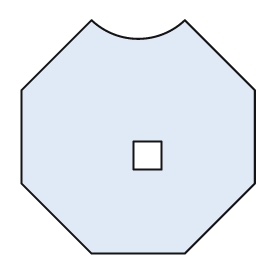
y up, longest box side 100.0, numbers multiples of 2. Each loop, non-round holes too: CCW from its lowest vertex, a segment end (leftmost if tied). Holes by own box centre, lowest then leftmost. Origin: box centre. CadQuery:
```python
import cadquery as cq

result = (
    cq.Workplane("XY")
    .moveTo(-20.0, -50.0)
    .lineTo(20.0, -50.0)
    .lineTo(50.0, -20.0)
    .lineTo(50.0, 20.0)
    .lineTo(20.0, 50.0)
    .threePointArc((0.0, 42.0), (-20.0, 50.0))
    .lineTo(-50.0, 20.0)
    .lineTo(-50.0, -20.0)
    .close()
    .moveTo(-2.0, -14.0)
    .lineTo(10.0, -14.0)
    .lineTo(10.0, -2.0)
    .lineTo(-2.0, -2.0)
    .close()
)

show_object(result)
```